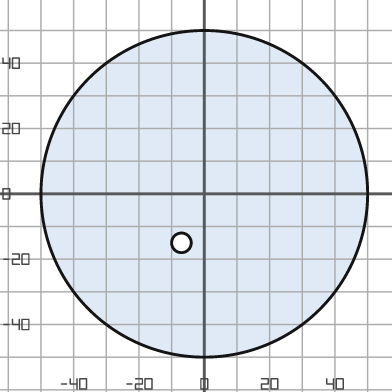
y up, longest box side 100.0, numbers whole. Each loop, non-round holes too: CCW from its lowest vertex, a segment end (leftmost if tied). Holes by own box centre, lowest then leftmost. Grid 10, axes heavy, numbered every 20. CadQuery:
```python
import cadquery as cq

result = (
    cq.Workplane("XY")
    .moveTo(0.0, 0.0)
    .circle(50.0)
    .moveTo(-7.0, -15.0)
    .circle(3.0)
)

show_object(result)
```